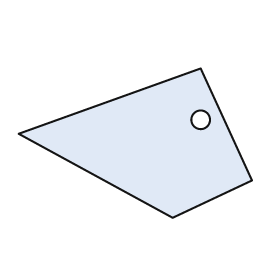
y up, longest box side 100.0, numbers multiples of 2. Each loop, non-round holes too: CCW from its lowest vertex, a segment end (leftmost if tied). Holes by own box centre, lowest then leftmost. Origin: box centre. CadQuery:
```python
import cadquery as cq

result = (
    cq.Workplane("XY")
    .moveTo(16.0, -32.0)
    .lineTo(50.0, -16.0)
    .lineTo(28.0, 32.0)
    .lineTo(-50.0, 4.0)
    .close()
    .moveTo(28.0, 10.0)
    .circle(4.0)
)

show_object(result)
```